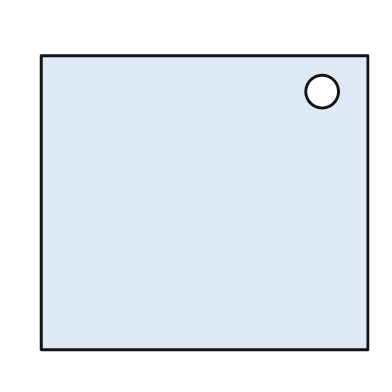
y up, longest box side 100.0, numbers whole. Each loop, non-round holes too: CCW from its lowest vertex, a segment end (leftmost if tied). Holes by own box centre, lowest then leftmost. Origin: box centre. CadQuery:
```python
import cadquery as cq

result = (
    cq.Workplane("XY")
    .moveTo(-50.0, -45.0)
    .lineTo(50.0, -45.0)
    .lineTo(50.0, 45.0)
    .lineTo(-50.0, 45.0)
    .close()
    .moveTo(36.0, 34.0)
    .circle(5.0)
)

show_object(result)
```